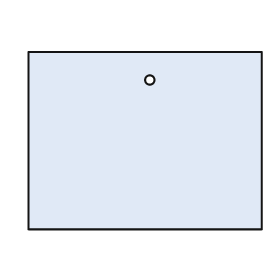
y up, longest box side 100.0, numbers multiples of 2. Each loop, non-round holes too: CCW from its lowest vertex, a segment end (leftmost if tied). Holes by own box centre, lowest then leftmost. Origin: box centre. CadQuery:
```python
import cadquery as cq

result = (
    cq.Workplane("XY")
    .moveTo(-50.0, -38.0)
    .lineTo(50.0, -38.0)
    .lineTo(50.0, 38.0)
    .lineTo(-50.0, 38.0)
    .close()
    .moveTo(2.0, 26.0)
    .circle(2.0)
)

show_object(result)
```